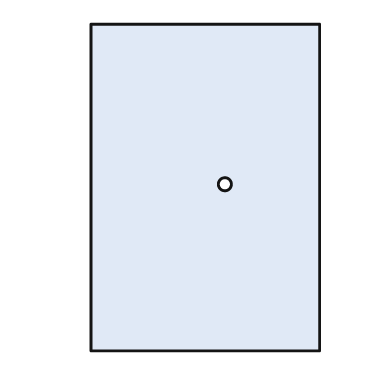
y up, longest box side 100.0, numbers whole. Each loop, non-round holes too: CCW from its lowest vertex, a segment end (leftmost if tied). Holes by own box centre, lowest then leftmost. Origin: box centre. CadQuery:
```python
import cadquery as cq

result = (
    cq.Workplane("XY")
    .moveTo(-35.0, -50.0)
    .lineTo(35.0, -50.0)
    .lineTo(35.0, 50.0)
    .lineTo(-35.0, 50.0)
    .close()
    .moveTo(6.0, 1.0)
    .circle(2.0)
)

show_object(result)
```